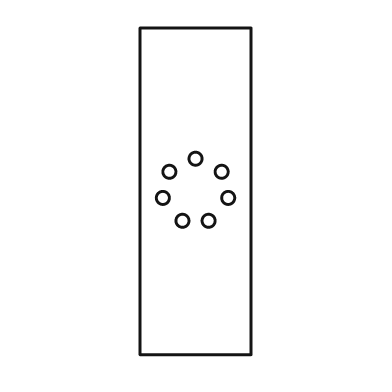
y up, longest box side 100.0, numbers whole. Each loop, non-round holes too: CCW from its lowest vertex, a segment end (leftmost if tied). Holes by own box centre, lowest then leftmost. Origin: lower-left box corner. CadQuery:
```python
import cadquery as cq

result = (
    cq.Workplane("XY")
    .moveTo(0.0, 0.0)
    .lineTo(34.0, 0.0)
    .lineTo(34.0, 100.0)
    .lineTo(0.0, 100.0)
    .close()
    .moveTo(13.0, 41.0)
    .circle(2.0)
    .moveTo(21.0, 41.0)
    .circle(2.0)
    .moveTo(7.0, 48.0)
    .circle(2.0)
    .moveTo(27.0, 48.0)
    .circle(2.0)
    .moveTo(9.0, 56.0)
    .circle(2.0)
    .moveTo(25.0, 56.0)
    .circle(2.0)
    .moveTo(17.0, 60.0)
    .circle(2.0)
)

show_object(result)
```